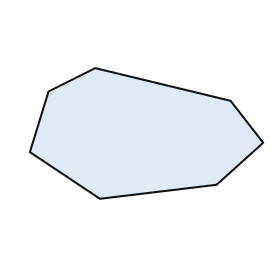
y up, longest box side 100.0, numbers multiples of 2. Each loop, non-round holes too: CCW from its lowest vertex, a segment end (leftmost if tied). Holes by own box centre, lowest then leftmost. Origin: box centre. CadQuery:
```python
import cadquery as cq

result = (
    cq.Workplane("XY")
    .moveTo(-20.0, -28.0)
    .lineTo(30.0, -22.0)
    .lineTo(50.0, -4.0)
    .lineTo(36.0, 14.0)
    .lineTo(-22.0, 28.0)
    .lineTo(-42.0, 18.0)
    .lineTo(-50.0, -8.0)
    .close()
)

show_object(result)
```